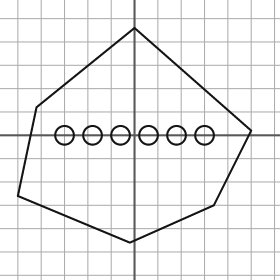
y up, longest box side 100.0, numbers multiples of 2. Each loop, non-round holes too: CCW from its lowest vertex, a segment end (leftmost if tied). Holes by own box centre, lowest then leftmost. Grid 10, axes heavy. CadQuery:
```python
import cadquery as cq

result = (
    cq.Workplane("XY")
    .moveTo(-2.0, -46.0)
    .lineTo(34.0, -30.0)
    .lineTo(50.0, 2.0)
    .lineTo(0.0, 46.0)
    .lineTo(-42.0, 12.0)
    .lineTo(-50.0, -26.0)
    .close()
    .moveTo(-30.0, 0.0)
    .circle(4.0)
    .moveTo(-18.0, 0.0)
    .circle(4.0)
    .moveTo(-6.0, 0.0)
    .circle(4.0)
    .moveTo(6.0, 0.0)
    .circle(4.0)
    .moveTo(18.0, 0.0)
    .circle(4.0)
    .moveTo(30.0, 0.0)
    .circle(4.0)
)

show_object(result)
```